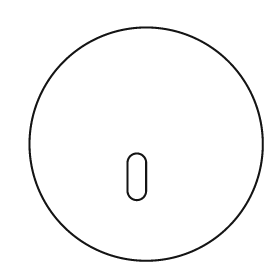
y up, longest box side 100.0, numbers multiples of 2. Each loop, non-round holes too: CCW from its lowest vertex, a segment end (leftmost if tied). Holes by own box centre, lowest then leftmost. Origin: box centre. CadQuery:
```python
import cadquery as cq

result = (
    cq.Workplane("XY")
    .moveTo(0.0, 0.0)
    .circle(50.0)
    .moveTo(-8.0, -20.0)
    .threePointArc((-4.0, -24.0), (0.0, -20.0))
    .lineTo(0.0, -8.0)
    .threePointArc((-4.0, -4.0), (-8.0, -8.0))
    .close()
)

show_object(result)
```